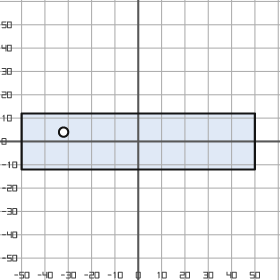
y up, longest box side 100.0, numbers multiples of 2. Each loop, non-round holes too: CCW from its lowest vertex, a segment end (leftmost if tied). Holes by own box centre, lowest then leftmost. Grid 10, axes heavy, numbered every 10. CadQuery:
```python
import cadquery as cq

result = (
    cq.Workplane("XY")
    .moveTo(-50.0, -12.0)
    .lineTo(50.0, -12.0)
    .lineTo(50.0, 12.0)
    .lineTo(-50.0, 12.0)
    .close()
    .moveTo(-32.0, 4.0)
    .circle(2.0)
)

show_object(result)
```